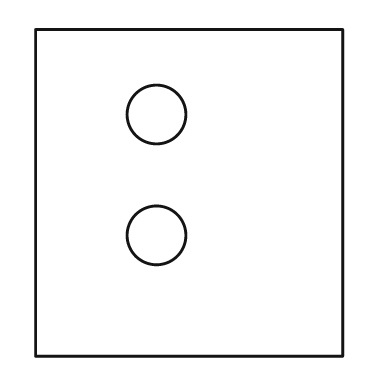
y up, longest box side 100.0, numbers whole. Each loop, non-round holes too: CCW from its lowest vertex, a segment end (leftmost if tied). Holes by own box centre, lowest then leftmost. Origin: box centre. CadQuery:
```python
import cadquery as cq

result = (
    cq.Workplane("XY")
    .moveTo(-47.0, -50.0)
    .lineTo(47.0, -50.0)
    .lineTo(47.0, 50.0)
    .lineTo(-47.0, 50.0)
    .close()
    .moveTo(-10.0, -13.0)
    .circle(9.0)
    .moveTo(-10.0, 24.0)
    .circle(9.0)
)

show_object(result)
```